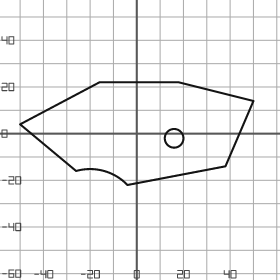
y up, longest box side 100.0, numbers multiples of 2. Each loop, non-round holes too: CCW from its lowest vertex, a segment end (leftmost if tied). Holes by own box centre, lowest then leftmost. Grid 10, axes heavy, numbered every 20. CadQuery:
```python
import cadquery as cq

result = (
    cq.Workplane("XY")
    .moveTo(-4.0, -22.0)
    .lineTo(38.0, -14.0)
    .lineTo(50.0, 14.0)
    .lineTo(18.0, 22.0)
    .lineTo(-16.0, 22.0)
    .lineTo(-50.0, 4.0)
    .lineTo(-26.0, -16.0)
    .threePointArc((-14.0, -16.0), (-4.0, -22.0))
    .close()
    .moveTo(16.0, -2.0)
    .circle(4.0)
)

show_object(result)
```